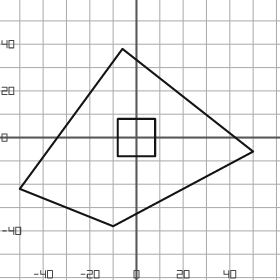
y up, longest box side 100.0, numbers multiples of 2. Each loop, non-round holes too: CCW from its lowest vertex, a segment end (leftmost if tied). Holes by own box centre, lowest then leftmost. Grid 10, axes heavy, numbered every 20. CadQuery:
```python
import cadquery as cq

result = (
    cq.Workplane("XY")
    .moveTo(-10.0, -38.0)
    .lineTo(50.0, -6.0)
    .lineTo(-6.0, 38.0)
    .lineTo(-50.0, -22.0)
    .close()
    .moveTo(-8.0, -8.0)
    .lineTo(8.0, -8.0)
    .lineTo(8.0, 8.0)
    .lineTo(-8.0, 8.0)
    .close()
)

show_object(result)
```